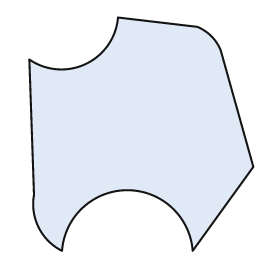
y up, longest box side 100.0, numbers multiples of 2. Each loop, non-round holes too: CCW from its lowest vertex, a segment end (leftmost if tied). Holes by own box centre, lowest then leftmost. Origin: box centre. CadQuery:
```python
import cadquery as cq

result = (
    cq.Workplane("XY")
    .moveTo(-34.0, -50.0)
    .threePointArc((-6.0, -24.0), (22.0, -50.0))
    .lineTo(48.0, -14.0)
    .lineTo(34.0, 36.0)
    .threePointArc((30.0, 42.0), (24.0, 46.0))
    .lineTo(-10.0, 50.0)
    .threePointArc((-24.0, 30.0), (-48.0, 32.0))
    .lineTo(-46.0, -26.0)
    .threePointArc((-44.0, -40.0), (-34.0, -50.0))
    .close()
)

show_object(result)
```